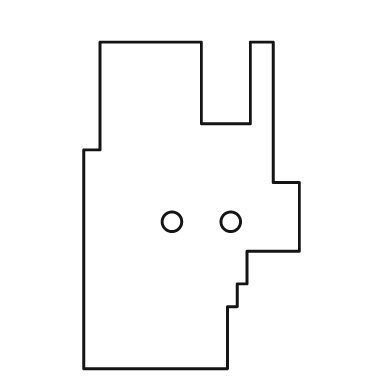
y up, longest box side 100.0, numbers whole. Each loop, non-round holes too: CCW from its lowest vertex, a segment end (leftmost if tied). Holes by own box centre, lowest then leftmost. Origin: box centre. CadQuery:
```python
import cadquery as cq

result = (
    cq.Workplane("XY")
    .moveTo(-33.0, -50.0)
    .lineTo(11.0, -50.0)
    .lineTo(11.0, -31.0)
    .lineTo(14.0, -31.0)
    .lineTo(14.0, -24.0)
    .lineTo(17.0, -24.0)
    .lineTo(17.0, -14.0)
    .lineTo(33.0, -14.0)
    .lineTo(33.0, 7.0)
    .lineTo(25.0, 7.0)
    .lineTo(25.0, 50.0)
    .lineTo(18.0, 50.0)
    .lineTo(18.0, 25.0)
    .lineTo(3.0, 25.0)
    .lineTo(3.0, 50.0)
    .lineTo(-28.0, 50.0)
    .lineTo(-28.0, 17.0)
    .lineTo(-33.0, 17.0)
    .close()
    .moveTo(-6.0, -5.0)
    .circle(3.0)
    .moveTo(12.0, -5.0)
    .circle(3.0)
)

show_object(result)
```